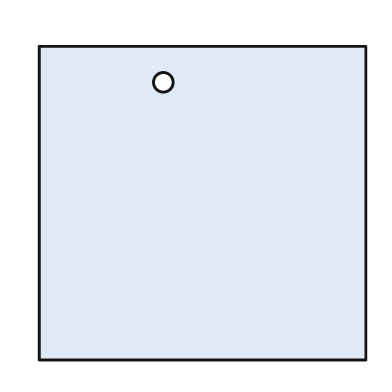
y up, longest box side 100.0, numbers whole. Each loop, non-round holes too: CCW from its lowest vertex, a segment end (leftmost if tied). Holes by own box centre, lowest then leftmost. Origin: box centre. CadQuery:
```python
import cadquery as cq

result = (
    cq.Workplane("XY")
    .moveTo(-50.0, -48.0)
    .lineTo(50.0, -48.0)
    .lineTo(50.0, 48.0)
    .lineTo(-50.0, 48.0)
    .close()
    .moveTo(-12.0, 37.0)
    .circle(3.0)
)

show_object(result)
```